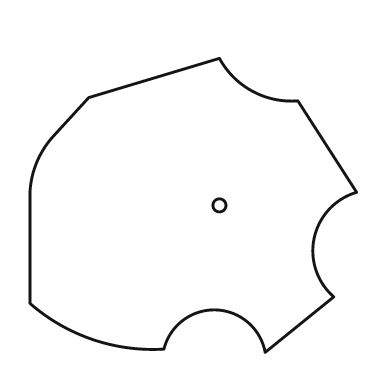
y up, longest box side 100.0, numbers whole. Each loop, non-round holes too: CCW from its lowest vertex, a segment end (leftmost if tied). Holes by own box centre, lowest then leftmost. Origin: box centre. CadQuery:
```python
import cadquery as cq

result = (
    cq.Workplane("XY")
    .moveTo(22.0, -45.0)
    .lineTo(43.0, -28.0)
    .threePointArc((37.0, -10.0), (50.0, 4.0))
    .lineTo(32.0, 32.0)
    .threePointArc((18.0, 35.0), (8.0, 45.0))
    .lineTo(-32.0, 33.0)
    .lineTo(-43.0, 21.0)
    .threePointArc((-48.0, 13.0), (-50.0, 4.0))
    .lineTo(-50.0, -30.0)
    .threePointArc((-31.0, -41.0), (-9.0, -44.0))
    .threePointArc((7.0, -32.0), (22.0, -45.0))
    .close()
    .moveTo(8.0, 0.0)
    .circle(2.0)
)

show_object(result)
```